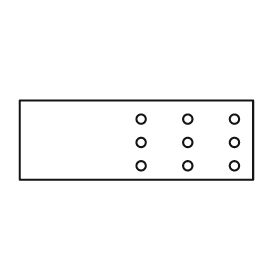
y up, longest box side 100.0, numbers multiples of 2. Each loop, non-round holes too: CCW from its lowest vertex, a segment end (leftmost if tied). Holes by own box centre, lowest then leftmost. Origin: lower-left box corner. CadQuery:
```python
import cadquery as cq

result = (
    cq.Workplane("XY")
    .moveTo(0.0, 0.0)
    .lineTo(100.0, 0.0)
    .lineTo(100.0, 34.0)
    .lineTo(0.0, 34.0)
    .close()
    .moveTo(52.0, 6.0)
    .circle(2.0)
    .moveTo(72.0, 6.0)
    .circle(2.0)
    .moveTo(92.0, 6.0)
    .circle(2.0)
    .moveTo(52.0, 16.0)
    .circle(2.0)
    .moveTo(72.0, 16.0)
    .circle(2.0)
    .moveTo(92.0, 16.0)
    .circle(2.0)
    .moveTo(52.0, 26.0)
    .circle(2.0)
    .moveTo(72.0, 26.0)
    .circle(2.0)
    .moveTo(92.0, 26.0)
    .circle(2.0)
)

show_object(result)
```